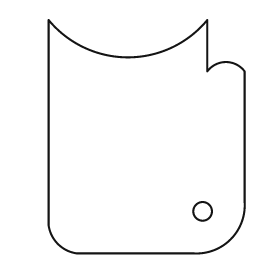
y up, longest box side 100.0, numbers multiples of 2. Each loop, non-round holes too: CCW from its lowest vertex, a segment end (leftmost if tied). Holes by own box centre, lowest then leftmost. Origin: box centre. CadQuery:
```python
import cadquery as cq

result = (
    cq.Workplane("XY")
    .moveTo(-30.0, -50.0)
    .lineTo(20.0, -50.0)
    .threePointArc((36.0, -44.0), (42.0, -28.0))
    .lineTo(42.0, 28.0)
    .threePointArc((34.0, 32.0), (26.0, 28.0))
    .lineTo(26.0, 50.0)
    .threePointArc((-8.0, 34.0), (-42.0, 50.0))
    .lineTo(-42.0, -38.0)
    .threePointArc((-38.0, -46.0), (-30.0, -50.0))
    .close()
    .moveTo(24.0, -32.0)
    .circle(4.0)
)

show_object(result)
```